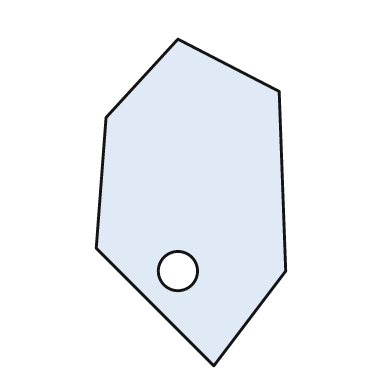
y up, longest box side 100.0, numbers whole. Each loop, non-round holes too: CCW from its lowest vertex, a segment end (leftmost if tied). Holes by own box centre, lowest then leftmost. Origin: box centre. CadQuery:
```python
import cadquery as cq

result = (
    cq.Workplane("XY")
    .moveTo(7.0, -50.0)
    .lineTo(29.0, -21.0)
    .lineTo(27.0, 34.0)
    .lineTo(-4.0, 50.0)
    .lineTo(-26.0, 26.0)
    .lineTo(-29.0, -14.0)
    .close()
    .moveTo(-4.0, -21.0)
    .circle(6.0)
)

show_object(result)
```